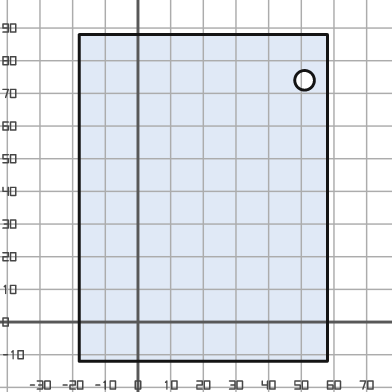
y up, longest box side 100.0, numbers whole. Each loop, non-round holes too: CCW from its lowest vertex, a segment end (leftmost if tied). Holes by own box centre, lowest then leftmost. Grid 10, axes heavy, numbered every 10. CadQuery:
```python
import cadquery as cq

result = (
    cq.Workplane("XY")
    .moveTo(-18.0, -12.0)
    .lineTo(58.0, -12.0)
    .lineTo(58.0, 88.0)
    .lineTo(-18.0, 88.0)
    .close()
    .moveTo(51.0, 74.0)
    .circle(3.0)
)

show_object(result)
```